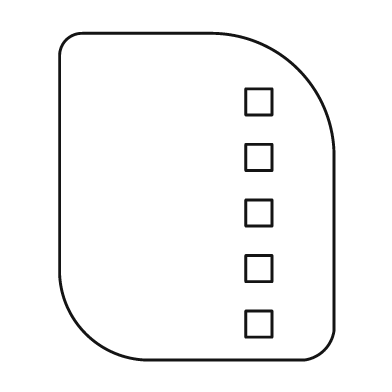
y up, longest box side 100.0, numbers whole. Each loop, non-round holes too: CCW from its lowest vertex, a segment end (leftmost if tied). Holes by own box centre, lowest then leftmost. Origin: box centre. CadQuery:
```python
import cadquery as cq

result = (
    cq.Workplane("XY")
    .moveTo(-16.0, -50.0)
    .lineTo(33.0, -50.0)
    .threePointArc((39.0, -47.0), (42.0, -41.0))
    .lineTo(42.0, 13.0)
    .threePointArc((31.0, 39.0), (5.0, 50.0))
    .lineTo(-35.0, 50.0)
    .threePointArc((-40.0, 48.0), (-42.0, 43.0))
    .lineTo(-42.0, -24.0)
    .threePointArc((-34.0, -42.0), (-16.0, -50.0))
    .close()
    .moveTo(15.0, -43.0)
    .lineTo(23.0, -43.0)
    .lineTo(23.0, -35.0)
    .lineTo(15.0, -35.0)
    .close()
    .moveTo(15.0, -26.0)
    .lineTo(23.0, -26.0)
    .lineTo(23.0, -18.0)
    .lineTo(15.0, -18.0)
    .close()
    .moveTo(15.0, -9.0)
    .lineTo(23.0, -9.0)
    .lineTo(23.0, -1.0)
    .lineTo(15.0, -1.0)
    .close()
    .moveTo(15.0, 8.0)
    .lineTo(23.0, 8.0)
    .lineTo(23.0, 16.0)
    .lineTo(15.0, 16.0)
    .close()
    .moveTo(15.0, 25.0)
    .lineTo(23.0, 25.0)
    .lineTo(23.0, 33.0)
    .lineTo(15.0, 33.0)
    .close()
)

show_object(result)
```